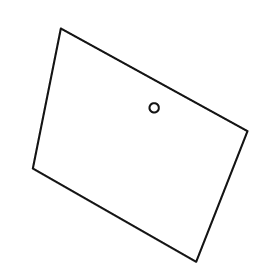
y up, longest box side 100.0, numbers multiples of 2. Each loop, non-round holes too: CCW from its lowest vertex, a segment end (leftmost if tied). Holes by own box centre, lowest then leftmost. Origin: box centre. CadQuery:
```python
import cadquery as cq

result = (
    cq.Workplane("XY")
    .moveTo(24.0, -50.0)
    .lineTo(46.0, 6.0)
    .lineTo(-34.0, 50.0)
    .lineTo(-46.0, -10.0)
    .close()
    .moveTo(6.0, 16.0)
    .circle(2.0)
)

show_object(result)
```